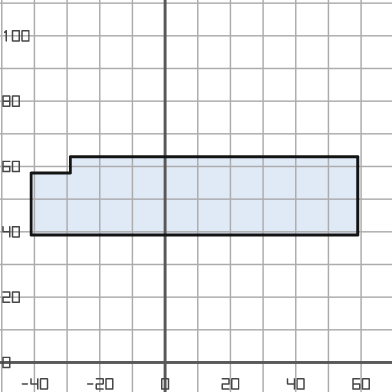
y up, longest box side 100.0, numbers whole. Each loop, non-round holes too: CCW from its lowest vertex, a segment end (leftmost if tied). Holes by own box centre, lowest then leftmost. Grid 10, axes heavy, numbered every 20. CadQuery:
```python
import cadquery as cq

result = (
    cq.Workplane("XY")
    .moveTo(-41.0, 39.0)
    .lineTo(59.0, 39.0)
    .lineTo(59.0, 63.0)
    .lineTo(-29.0, 63.0)
    .lineTo(-29.0, 58.0)
    .lineTo(-41.0, 58.0)
    .close()
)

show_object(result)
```